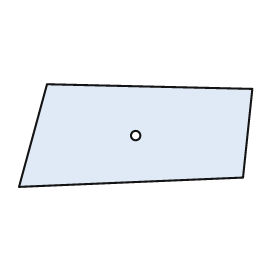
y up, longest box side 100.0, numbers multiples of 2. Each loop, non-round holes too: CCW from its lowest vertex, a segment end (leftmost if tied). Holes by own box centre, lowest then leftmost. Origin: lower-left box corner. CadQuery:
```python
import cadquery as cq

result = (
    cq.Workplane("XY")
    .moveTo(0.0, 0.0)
    .lineTo(96.0, 4.0)
    .lineTo(100.0, 42.0)
    .lineTo(12.0, 44.0)
    .close()
    .moveTo(50.0, 22.0)
    .circle(2.0)
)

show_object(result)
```